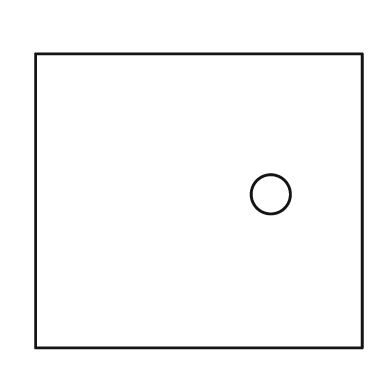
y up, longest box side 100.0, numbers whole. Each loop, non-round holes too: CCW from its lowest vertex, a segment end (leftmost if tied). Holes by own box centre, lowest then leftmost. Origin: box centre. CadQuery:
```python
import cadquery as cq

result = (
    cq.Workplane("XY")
    .moveTo(-50.0, -45.0)
    .lineTo(50.0, -45.0)
    .lineTo(50.0, 45.0)
    .lineTo(-50.0, 45.0)
    .close()
    .moveTo(22.0, 2.0)
    .circle(6.0)
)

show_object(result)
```